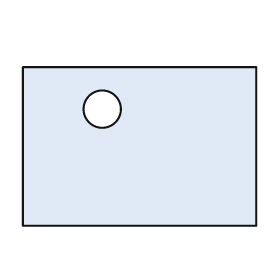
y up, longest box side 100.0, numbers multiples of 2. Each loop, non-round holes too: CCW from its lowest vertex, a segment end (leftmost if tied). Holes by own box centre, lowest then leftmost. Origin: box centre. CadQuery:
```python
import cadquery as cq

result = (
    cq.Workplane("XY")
    .moveTo(-50.0, -34.0)
    .lineTo(50.0, -34.0)
    .lineTo(50.0, 34.0)
    .lineTo(-50.0, 34.0)
    .close()
    .moveTo(-16.0, 16.0)
    .circle(8.0)
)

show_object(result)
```